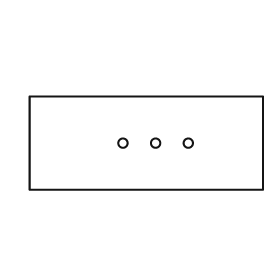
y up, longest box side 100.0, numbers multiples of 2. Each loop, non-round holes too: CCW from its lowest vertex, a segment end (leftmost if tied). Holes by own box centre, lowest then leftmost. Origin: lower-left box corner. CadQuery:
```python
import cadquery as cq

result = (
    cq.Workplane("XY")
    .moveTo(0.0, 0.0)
    .lineTo(100.0, 0.0)
    .lineTo(100.0, 40.0)
    .lineTo(0.0, 40.0)
    .close()
    .moveTo(40.0, 20.0)
    .circle(2.0)
    .moveTo(54.0, 20.0)
    .circle(2.0)
    .moveTo(68.0, 20.0)
    .circle(2.0)
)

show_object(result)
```